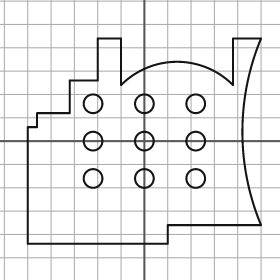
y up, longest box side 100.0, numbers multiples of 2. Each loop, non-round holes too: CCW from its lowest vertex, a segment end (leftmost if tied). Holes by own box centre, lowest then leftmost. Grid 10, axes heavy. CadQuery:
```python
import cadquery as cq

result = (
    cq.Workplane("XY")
    .moveTo(-50.0, -44.0)
    .lineTo(10.0, -44.0)
    .lineTo(10.0, -36.0)
    .lineTo(50.0, -36.0)
    .threePointArc((42.0, 4.0), (50.0, 44.0))
    .lineTo(38.0, 44.0)
    .lineTo(38.0, 24.0)
    .threePointArc((14.0, 34.0), (-10.0, 24.0))
    .lineTo(-10.0, 44.0)
    .lineTo(-20.0, 44.0)
    .lineTo(-20.0, 26.0)
    .lineTo(-32.0, 26.0)
    .lineTo(-32.0, 12.0)
    .lineTo(-46.0, 12.0)
    .lineTo(-46.0, 6.0)
    .lineTo(-50.0, 6.0)
    .close()
    .moveTo(-22.0, -16.0)
    .circle(4.0)
    .moveTo(0.0, -16.0)
    .circle(4.0)
    .moveTo(22.0, -16.0)
    .circle(4.0)
    .moveTo(-22.0, 0.0)
    .circle(4.0)
    .moveTo(0.0, 0.0)
    .circle(4.0)
    .moveTo(22.0, 0.0)
    .circle(4.0)
    .moveTo(-22.0, 16.0)
    .circle(4.0)
    .moveTo(0.0, 16.0)
    .circle(4.0)
    .moveTo(22.0, 16.0)
    .circle(4.0)
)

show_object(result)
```